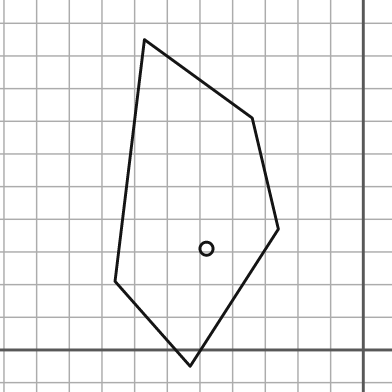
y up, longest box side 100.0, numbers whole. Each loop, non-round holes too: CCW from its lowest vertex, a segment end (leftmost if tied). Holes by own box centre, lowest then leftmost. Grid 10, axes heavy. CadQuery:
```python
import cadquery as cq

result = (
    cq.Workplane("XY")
    .moveTo(-53.0, -5.0)
    .lineTo(-26.0, 37.0)
    .lineTo(-34.0, 71.0)
    .lineTo(-67.0, 95.0)
    .lineTo(-76.0, 21.0)
    .close()
    .moveTo(-48.0, 31.0)
    .circle(2.0)
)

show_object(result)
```